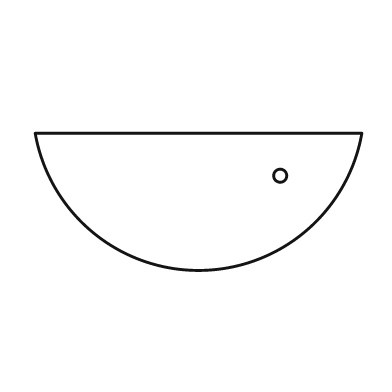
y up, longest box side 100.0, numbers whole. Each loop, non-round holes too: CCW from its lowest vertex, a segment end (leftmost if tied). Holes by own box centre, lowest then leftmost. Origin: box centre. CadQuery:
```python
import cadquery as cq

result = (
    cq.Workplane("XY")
    .moveTo(-50.0, 21.0)
    .threePointArc((0.0, -21.0), (50.0, 21.0))
    .close()
    .moveTo(25.0, 8.0)
    .circle(2.0)
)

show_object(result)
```